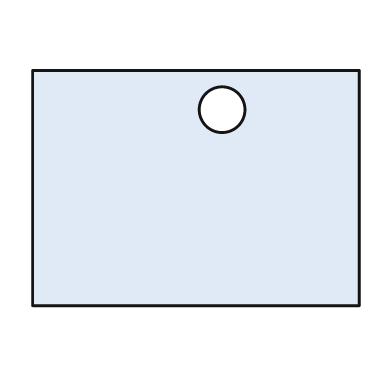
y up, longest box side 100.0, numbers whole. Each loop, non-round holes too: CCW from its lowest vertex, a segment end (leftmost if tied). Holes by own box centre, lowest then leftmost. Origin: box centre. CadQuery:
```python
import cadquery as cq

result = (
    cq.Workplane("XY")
    .moveTo(-50.0, -36.0)
    .lineTo(50.0, -36.0)
    .lineTo(50.0, 36.0)
    .lineTo(-50.0, 36.0)
    .close()
    .moveTo(8.0, 24.0)
    .circle(7.0)
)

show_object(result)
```